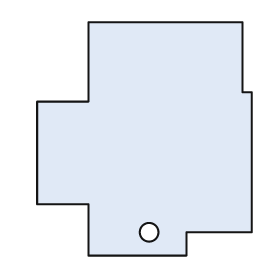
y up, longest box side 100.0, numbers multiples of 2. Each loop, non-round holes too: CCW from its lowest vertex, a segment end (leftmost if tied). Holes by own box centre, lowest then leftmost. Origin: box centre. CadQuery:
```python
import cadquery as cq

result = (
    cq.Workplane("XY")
    .moveTo(-24.0, -50.0)
    .lineTo(18.0, -50.0)
    .lineTo(18.0, -40.0)
    .lineTo(46.0, -40.0)
    .lineTo(46.0, 20.0)
    .lineTo(42.0, 20.0)
    .lineTo(42.0, 50.0)
    .lineTo(-24.0, 50.0)
    .lineTo(-24.0, 16.0)
    .lineTo(-46.0, 16.0)
    .lineTo(-46.0, -28.0)
    .lineTo(-24.0, -28.0)
    .close()
    .moveTo(2.0, -40.0)
    .circle(4.0)
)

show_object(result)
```